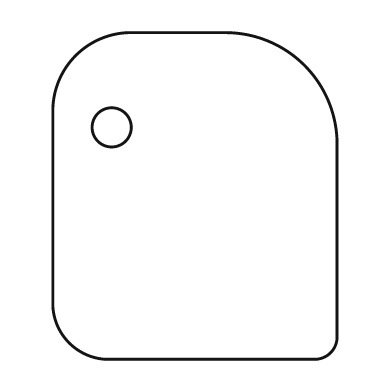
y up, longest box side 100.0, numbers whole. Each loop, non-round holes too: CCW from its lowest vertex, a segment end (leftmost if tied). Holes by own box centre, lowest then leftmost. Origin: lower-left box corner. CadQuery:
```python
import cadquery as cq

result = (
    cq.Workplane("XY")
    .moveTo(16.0, 0.0)
    .lineTo(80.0, 0.0)
    .threePointArc((85.0, 2.0), (87.0, 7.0))
    .lineTo(87.0, 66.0)
    .threePointArc((77.0, 90.0), (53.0, 100.0))
    .lineTo(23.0, 100.0)
    .threePointArc((7.0, 93.0), (0.0, 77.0))
    .lineTo(0.0, 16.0)
    .threePointArc((5.0, 5.0), (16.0, 0.0))
    .close()
    .moveTo(18.0, 71.0)
    .circle(6.0)
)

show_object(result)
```